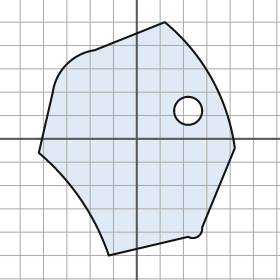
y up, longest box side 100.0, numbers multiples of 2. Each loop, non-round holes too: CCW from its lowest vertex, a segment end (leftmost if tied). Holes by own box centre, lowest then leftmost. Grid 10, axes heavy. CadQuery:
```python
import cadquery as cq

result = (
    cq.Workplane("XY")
    .moveTo(-12.0, -50.0)
    .lineTo(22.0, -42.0)
    .threePointArc((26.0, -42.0), (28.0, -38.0))
    .lineTo(42.0, -4.0)
    .threePointArc((32.0, 26.0), (12.0, 50.0))
    .lineTo(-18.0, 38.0)
    .threePointArc((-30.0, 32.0), (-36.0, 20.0))
    .lineTo(-42.0, -6.0)
    .threePointArc((-24.0, -26.0), (-12.0, -50.0))
    .close()
    .moveTo(22.0, 12.0)
    .circle(6.0)
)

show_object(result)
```